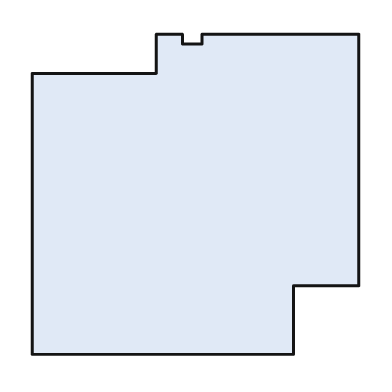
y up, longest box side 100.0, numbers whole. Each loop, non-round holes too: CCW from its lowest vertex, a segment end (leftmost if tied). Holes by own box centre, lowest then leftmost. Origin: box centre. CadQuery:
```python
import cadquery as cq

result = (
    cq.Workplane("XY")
    .moveTo(-50.0, -49.0)
    .lineTo(30.0, -49.0)
    .lineTo(30.0, -28.0)
    .lineTo(50.0, -28.0)
    .lineTo(50.0, 49.0)
    .lineTo(2.0, 49.0)
    .lineTo(2.0, 46.0)
    .lineTo(-4.0, 46.0)
    .lineTo(-4.0, 49.0)
    .lineTo(-12.0, 49.0)
    .lineTo(-12.0, 37.0)
    .lineTo(-50.0, 37.0)
    .close()
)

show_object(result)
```